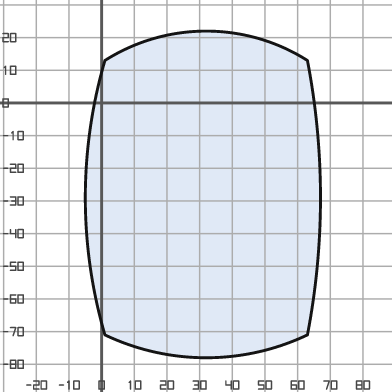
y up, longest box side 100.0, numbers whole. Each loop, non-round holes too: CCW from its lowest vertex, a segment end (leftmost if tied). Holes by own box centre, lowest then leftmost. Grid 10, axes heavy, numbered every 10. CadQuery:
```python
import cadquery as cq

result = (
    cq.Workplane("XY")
    .moveTo(1.0, -71.0)
    .threePointArc((32.0, -78.0), (63.0, -71.0))
    .threePointArc((67.0, -29.0), (63.0, 13.0))
    .threePointArc((32.0, 22.0), (1.0, 13.0))
    .threePointArc((-5.0, -29.0), (1.0, -71.0))
    .close()
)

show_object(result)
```